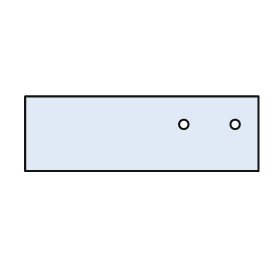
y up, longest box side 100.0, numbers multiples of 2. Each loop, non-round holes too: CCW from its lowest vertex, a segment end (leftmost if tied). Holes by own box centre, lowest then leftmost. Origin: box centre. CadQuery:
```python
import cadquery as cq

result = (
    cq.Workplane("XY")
    .moveTo(-50.0, -16.0)
    .lineTo(50.0, -16.0)
    .lineTo(50.0, 16.0)
    .lineTo(-50.0, 16.0)
    .close()
    .moveTo(18.0, 4.0)
    .circle(2.0)
    .moveTo(40.0, 4.0)
    .circle(2.0)
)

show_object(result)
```